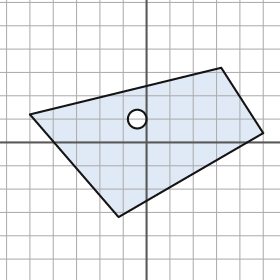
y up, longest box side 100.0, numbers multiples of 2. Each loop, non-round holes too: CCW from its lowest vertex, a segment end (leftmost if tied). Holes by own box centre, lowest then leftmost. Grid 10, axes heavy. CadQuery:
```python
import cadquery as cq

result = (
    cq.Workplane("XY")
    .moveTo(-12.0, -32.0)
    .lineTo(50.0, 4.0)
    .lineTo(32.0, 32.0)
    .lineTo(-50.0, 12.0)
    .close()
    .moveTo(-4.0, 10.0)
    .circle(4.0)
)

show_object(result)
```